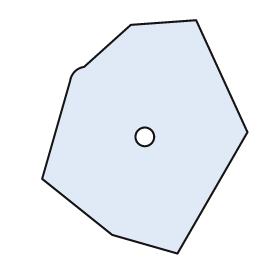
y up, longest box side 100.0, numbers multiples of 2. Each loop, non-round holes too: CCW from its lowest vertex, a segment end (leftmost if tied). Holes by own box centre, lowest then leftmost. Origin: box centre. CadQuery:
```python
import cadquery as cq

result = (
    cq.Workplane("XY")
    .moveTo(14.0, -50.0)
    .lineTo(44.0, 2.0)
    .lineTo(22.0, 50.0)
    .lineTo(-6.0, 48.0)
    .lineTo(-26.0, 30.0)
    .threePointArc((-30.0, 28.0), (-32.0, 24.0))
    .lineTo(-44.0, -18.0)
    .lineTo(-14.0, -42.0)
    .close()
    .moveTo(0.0, 0.0)
    .circle(4.0)
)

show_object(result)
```